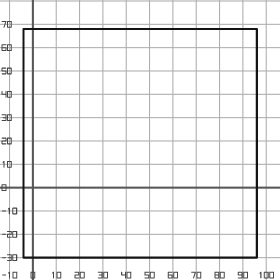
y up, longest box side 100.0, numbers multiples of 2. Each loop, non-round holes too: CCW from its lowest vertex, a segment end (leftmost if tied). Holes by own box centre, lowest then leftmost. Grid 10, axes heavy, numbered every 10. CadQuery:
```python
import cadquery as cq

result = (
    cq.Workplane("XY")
    .moveTo(-4.0, -30.0)
    .lineTo(96.0, -30.0)
    .lineTo(96.0, 68.0)
    .lineTo(-4.0, 68.0)
    .close()
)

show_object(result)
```